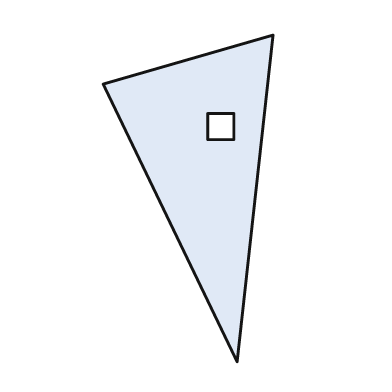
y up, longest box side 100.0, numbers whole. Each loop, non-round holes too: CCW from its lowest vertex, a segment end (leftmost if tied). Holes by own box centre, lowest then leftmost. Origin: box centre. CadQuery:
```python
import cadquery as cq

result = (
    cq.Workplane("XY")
    .moveTo(15.0, -50.0)
    .lineTo(26.0, 50.0)
    .lineTo(-26.0, 35.0)
    .close()
    .moveTo(6.0, 18.0)
    .lineTo(14.0, 18.0)
    .lineTo(14.0, 26.0)
    .lineTo(6.0, 26.0)
    .close()
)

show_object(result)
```